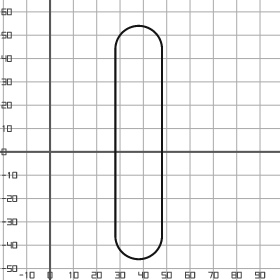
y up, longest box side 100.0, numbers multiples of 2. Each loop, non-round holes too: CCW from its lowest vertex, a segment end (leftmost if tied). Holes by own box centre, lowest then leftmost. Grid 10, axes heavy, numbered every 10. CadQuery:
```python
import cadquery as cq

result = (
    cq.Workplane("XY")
    .moveTo(28.0, -36.0)
    .threePointArc((38.0, -46.0), (48.0, -36.0))
    .lineTo(48.0, 44.0)
    .threePointArc((38.0, 54.0), (28.0, 44.0))
    .close()
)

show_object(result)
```